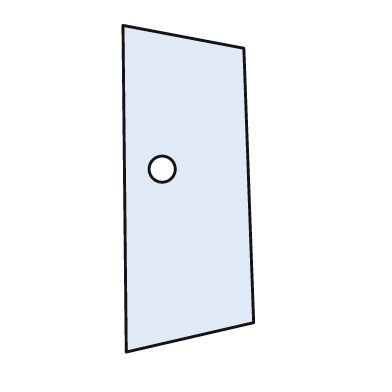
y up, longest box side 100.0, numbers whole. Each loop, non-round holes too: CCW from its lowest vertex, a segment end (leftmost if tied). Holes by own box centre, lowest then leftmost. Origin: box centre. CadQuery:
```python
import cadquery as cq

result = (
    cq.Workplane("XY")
    .moveTo(-19.0, -50.0)
    .lineTo(20.0, -41.0)
    .lineTo(17.0, 43.0)
    .lineTo(-20.0, 50.0)
    .close()
    .moveTo(-8.0, 6.0)
    .circle(4.0)
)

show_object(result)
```